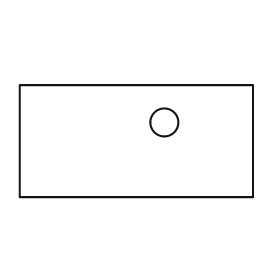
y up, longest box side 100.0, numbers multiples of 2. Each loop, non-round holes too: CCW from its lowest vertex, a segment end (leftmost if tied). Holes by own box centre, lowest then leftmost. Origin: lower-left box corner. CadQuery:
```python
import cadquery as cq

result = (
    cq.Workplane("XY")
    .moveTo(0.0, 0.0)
    .lineTo(100.0, 0.0)
    .lineTo(100.0, 48.0)
    .lineTo(0.0, 48.0)
    .close()
    .moveTo(62.0, 32.0)
    .circle(6.0)
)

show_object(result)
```